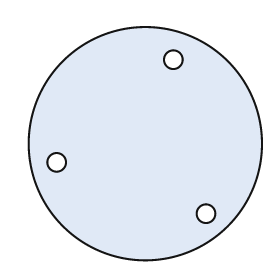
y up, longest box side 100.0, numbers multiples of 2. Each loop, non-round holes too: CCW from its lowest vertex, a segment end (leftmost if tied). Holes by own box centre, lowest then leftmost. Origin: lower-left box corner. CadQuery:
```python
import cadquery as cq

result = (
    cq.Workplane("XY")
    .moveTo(50.0, 50.0)
    .circle(50.0)
    .moveTo(76.0, 20.0)
    .circle(4.0)
    .moveTo(12.0, 42.0)
    .circle(4.0)
    .moveTo(62.0, 86.0)
    .circle(4.0)
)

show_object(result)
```